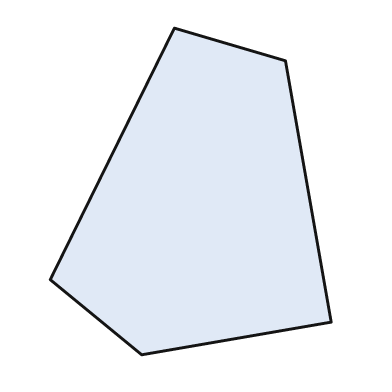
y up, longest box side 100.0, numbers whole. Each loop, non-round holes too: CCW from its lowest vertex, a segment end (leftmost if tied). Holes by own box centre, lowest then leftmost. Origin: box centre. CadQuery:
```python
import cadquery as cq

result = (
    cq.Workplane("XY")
    .moveTo(-15.0, -50.0)
    .lineTo(43.0, -40.0)
    .lineTo(29.0, 40.0)
    .lineTo(-5.0, 50.0)
    .lineTo(-43.0, -27.0)
    .close()
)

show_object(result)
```